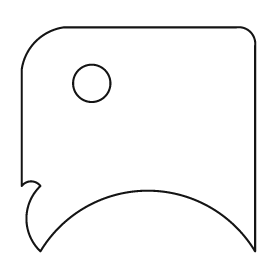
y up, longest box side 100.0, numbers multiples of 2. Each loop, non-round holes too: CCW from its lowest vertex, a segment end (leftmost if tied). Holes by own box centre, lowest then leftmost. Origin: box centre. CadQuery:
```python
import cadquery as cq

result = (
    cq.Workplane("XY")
    .moveTo(-42.0, -48.0)
    .threePointArc((4.0, -22.0), (50.0, -48.0))
    .lineTo(50.0, 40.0)
    .threePointArc((48.0, 46.0), (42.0, 48.0))
    .lineTo(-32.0, 48.0)
    .threePointArc((-44.0, 42.0), (-50.0, 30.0))
    .lineTo(-50.0, -20.0)
    .threePointArc((-46.0, -18.0), (-42.0, -20.0))
    .threePointArc((-48.0, -34.0), (-42.0, -48.0))
    .close()
    .moveTo(-20.0, 24.0)
    .circle(8.0)
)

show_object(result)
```